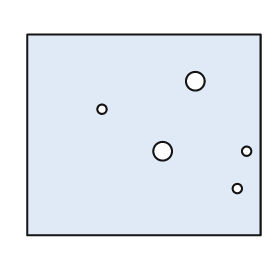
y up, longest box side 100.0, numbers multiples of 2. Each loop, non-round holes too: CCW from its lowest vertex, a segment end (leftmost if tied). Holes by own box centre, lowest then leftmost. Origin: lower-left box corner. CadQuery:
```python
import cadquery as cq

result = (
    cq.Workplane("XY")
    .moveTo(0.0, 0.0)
    .lineTo(100.0, 0.0)
    .lineTo(100.0, 86.0)
    .lineTo(0.0, 86.0)
    .close()
    .moveTo(90.0, 20.0)
    .circle(2.0)
    .moveTo(58.0, 36.0)
    .circle(4.0)
    .moveTo(94.0, 36.0)
    .circle(2.0)
    .moveTo(32.0, 54.0)
    .circle(2.0)
    .moveTo(72.0, 66.0)
    .circle(4.0)
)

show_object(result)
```